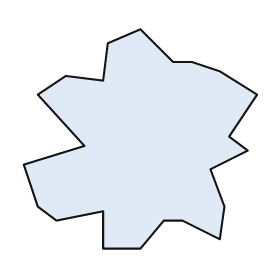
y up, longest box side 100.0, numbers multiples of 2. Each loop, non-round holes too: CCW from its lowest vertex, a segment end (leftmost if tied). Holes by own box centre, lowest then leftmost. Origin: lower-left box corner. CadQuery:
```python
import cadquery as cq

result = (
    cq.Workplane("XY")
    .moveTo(34.0, 0.0)
    .lineTo(50.0, 0.0)
    .lineTo(60.0, 12.0)
    .lineTo(68.0, 12.0)
    .lineTo(84.0, 4.0)
    .lineTo(86.0, 18.0)
    .lineTo(80.0, 34.0)
    .lineTo(96.0, 42.0)
    .lineTo(88.0, 48.0)
    .lineTo(100.0, 66.0)
    .lineTo(84.0, 76.0)
    .lineTo(72.0, 80.0)
    .lineTo(64.0, 80.0)
    .lineTo(50.0, 94.0)
    .lineTo(36.0, 88.0)
    .lineTo(34.0, 72.0)
    .lineTo(18.0, 74.0)
    .lineTo(6.0, 66.0)
    .lineTo(26.0, 44.0)
    .lineTo(0.0, 36.0)
    .lineTo(6.0, 18.0)
    .lineTo(14.0, 12.0)
    .lineTo(34.0, 16.0)
    .close()
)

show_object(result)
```